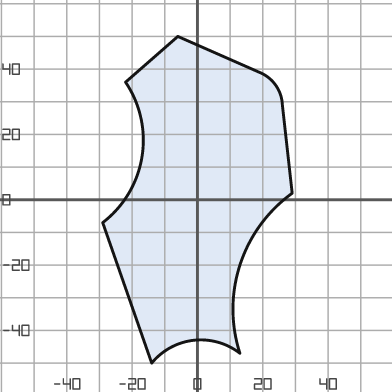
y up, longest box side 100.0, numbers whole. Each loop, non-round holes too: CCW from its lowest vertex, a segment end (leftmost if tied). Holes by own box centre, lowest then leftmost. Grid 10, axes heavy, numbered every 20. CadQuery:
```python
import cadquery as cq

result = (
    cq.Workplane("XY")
    .moveTo(-14.0, -50.0)
    .threePointArc((-1.0, -43.0), (13.0, -47.0))
    .threePointArc((13.0, -20.0), (29.0, 2.0))
    .lineTo(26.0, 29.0)
    .threePointArc((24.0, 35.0), (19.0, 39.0))
    .lineTo(-6.0, 50.0)
    .lineTo(-22.0, 36.0)
    .threePointArc((-17.0, 13.0), (-29.0, -7.0))
    .close()
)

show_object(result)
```